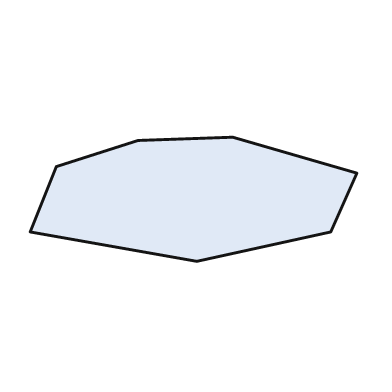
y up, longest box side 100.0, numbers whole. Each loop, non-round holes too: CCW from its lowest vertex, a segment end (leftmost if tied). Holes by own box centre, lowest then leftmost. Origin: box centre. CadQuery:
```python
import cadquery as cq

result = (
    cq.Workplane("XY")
    .moveTo(1.0, -19.0)
    .lineTo(42.0, -10.0)
    .lineTo(50.0, 8.0)
    .lineTo(12.0, 19.0)
    .lineTo(-17.0, 18.0)
    .lineTo(-42.0, 10.0)
    .lineTo(-50.0, -10.0)
    .close()
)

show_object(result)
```